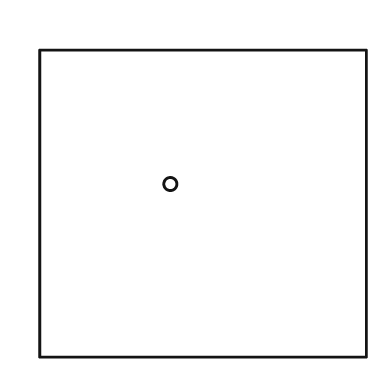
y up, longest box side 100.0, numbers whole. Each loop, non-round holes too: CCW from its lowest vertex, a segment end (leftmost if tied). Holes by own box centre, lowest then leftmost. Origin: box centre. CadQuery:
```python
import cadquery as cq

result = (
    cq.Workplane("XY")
    .moveTo(-50.0, -47.0)
    .lineTo(50.0, -47.0)
    .lineTo(50.0, 47.0)
    .lineTo(-50.0, 47.0)
    .close()
    .moveTo(-10.0, 6.0)
    .circle(2.0)
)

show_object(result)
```